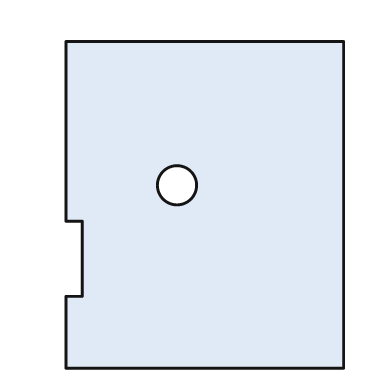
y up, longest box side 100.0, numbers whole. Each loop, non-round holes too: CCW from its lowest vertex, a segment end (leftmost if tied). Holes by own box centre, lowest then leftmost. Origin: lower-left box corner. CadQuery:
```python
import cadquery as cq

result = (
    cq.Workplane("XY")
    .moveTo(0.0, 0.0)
    .lineTo(85.0, 0.0)
    .lineTo(85.0, 100.0)
    .lineTo(0.0, 100.0)
    .lineTo(0.0, 45.0)
    .lineTo(5.0, 45.0)
    .lineTo(5.0, 22.0)
    .lineTo(0.0, 22.0)
    .close()
    .moveTo(34.0, 56.0)
    .circle(6.0)
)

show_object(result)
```